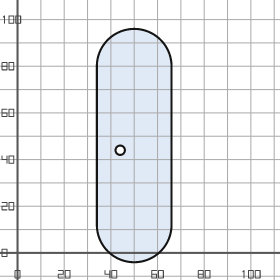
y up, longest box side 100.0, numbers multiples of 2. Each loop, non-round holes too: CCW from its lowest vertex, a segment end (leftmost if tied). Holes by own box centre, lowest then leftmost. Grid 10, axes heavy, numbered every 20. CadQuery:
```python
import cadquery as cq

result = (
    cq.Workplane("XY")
    .moveTo(34.0, 12.0)
    .threePointArc((50.0, -4.0), (66.0, 12.0))
    .lineTo(66.0, 80.0)
    .threePointArc((50.0, 96.0), (34.0, 80.0))
    .close()
    .moveTo(44.0, 44.0)
    .circle(2.0)
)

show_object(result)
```